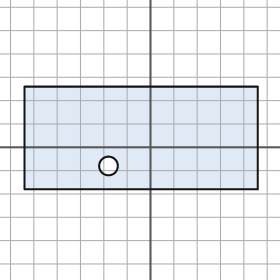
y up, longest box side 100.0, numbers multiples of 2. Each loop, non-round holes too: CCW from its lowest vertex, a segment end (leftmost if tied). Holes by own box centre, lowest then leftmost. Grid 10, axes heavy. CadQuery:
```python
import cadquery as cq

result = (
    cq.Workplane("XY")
    .moveTo(-54.0, -18.0)
    .lineTo(46.0, -18.0)
    .lineTo(46.0, 26.0)
    .lineTo(-54.0, 26.0)
    .close()
    .moveTo(-18.0, -8.0)
    .circle(4.0)
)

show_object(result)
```